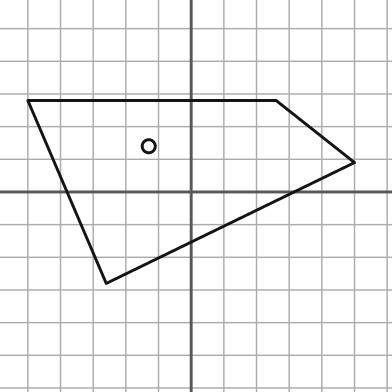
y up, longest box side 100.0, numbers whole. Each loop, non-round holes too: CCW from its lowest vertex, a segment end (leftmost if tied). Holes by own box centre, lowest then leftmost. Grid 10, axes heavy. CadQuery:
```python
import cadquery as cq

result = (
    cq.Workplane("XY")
    .moveTo(-26.0, -28.0)
    .lineTo(50.0, 9.0)
    .lineTo(26.0, 28.0)
    .lineTo(-50.0, 28.0)
    .close()
    .moveTo(-13.0, 14.0)
    .circle(2.0)
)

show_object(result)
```